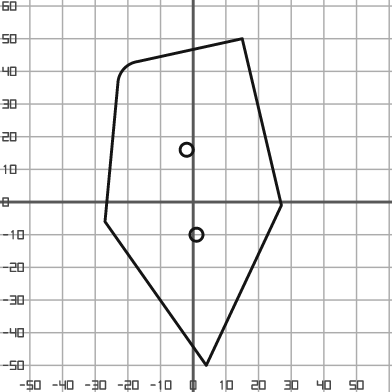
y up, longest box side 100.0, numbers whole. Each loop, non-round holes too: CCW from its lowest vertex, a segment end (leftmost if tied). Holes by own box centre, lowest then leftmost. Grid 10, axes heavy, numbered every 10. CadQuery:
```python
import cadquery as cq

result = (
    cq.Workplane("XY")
    .moveTo(4.0, -50.0)
    .lineTo(27.0, -1.0)
    .lineTo(15.0, 50.0)
    .lineTo(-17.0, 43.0)
    .threePointArc((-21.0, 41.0), (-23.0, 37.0))
    .lineTo(-27.0, -6.0)
    .close()
    .moveTo(1.0, -10.0)
    .circle(2.0)
    .moveTo(-2.0, 16.0)
    .circle(2.0)
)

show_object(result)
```